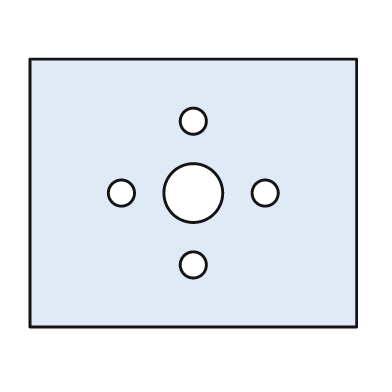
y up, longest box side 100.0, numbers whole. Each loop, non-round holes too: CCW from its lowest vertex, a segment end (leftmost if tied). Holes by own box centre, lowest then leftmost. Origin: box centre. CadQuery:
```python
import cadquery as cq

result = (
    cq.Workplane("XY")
    .moveTo(-50.0, -41.0)
    .lineTo(50.0, -41.0)
    .lineTo(50.0, 41.0)
    .lineTo(-50.0, 41.0)
    .close()
    .moveTo(0.0, -22.0)
    .circle(4.0)
    .moveTo(-22.0, 0.0)
    .circle(4.0)
    .moveTo(0.0, 0.0)
    .circle(9.0)
    .moveTo(22.0, 0.0)
    .circle(4.0)
    .moveTo(0.0, 22.0)
    .circle(4.0)
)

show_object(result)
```